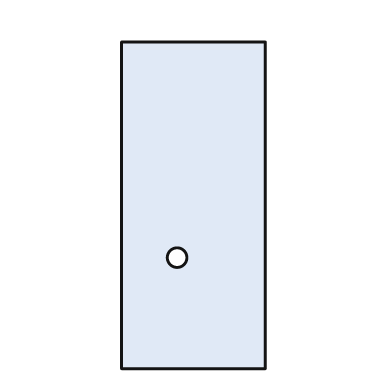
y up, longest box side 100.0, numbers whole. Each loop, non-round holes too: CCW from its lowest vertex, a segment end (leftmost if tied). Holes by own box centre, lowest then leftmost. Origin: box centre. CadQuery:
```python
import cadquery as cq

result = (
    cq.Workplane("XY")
    .moveTo(-22.0, -50.0)
    .lineTo(22.0, -50.0)
    .lineTo(22.0, 50.0)
    .lineTo(-22.0, 50.0)
    .close()
    .moveTo(-5.0, -16.0)
    .circle(3.0)
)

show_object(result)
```